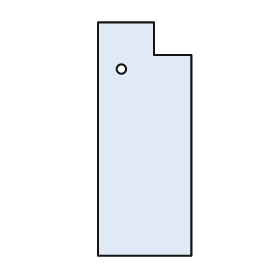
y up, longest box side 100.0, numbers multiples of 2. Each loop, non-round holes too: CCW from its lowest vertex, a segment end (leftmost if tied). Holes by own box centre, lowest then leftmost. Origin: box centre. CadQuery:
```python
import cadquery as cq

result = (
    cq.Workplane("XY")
    .moveTo(-20.0, -50.0)
    .lineTo(20.0, -50.0)
    .lineTo(20.0, 36.0)
    .lineTo(4.0, 36.0)
    .lineTo(4.0, 50.0)
    .lineTo(-20.0, 50.0)
    .close()
    .moveTo(-10.0, 30.0)
    .circle(2.0)
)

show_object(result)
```